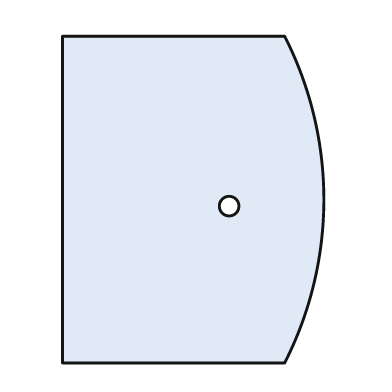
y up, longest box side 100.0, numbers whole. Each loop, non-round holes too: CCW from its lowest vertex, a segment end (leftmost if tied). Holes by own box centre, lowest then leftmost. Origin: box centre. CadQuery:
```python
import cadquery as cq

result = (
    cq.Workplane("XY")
    .moveTo(-40.0, -50.0)
    .lineTo(28.0, -50.0)
    .threePointArc((40.0, 0.0), (28.0, 50.0))
    .lineTo(-40.0, 50.0)
    .close()
    .moveTo(11.0, -2.0)
    .circle(3.0)
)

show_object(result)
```